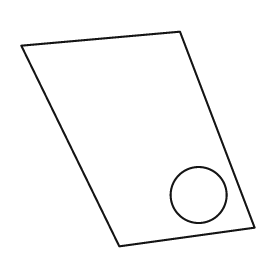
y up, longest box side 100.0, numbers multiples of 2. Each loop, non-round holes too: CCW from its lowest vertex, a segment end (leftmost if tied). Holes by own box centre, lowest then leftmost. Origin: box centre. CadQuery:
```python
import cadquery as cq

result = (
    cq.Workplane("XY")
    .moveTo(-8.0, -46.0)
    .lineTo(50.0, -38.0)
    .lineTo(18.0, 46.0)
    .lineTo(-50.0, 40.0)
    .close()
    .moveTo(26.0, -24.0)
    .circle(12.0)
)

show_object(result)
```